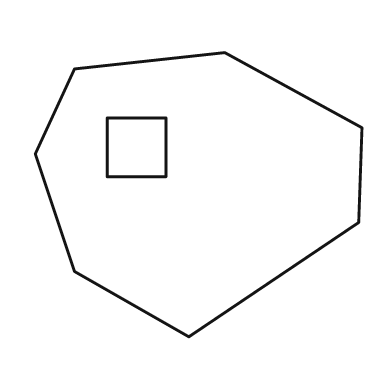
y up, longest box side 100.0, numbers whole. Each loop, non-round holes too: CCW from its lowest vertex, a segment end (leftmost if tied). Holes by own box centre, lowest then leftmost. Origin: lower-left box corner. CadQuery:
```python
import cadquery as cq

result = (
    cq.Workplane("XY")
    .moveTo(47.0, 0.0)
    .lineTo(99.0, 35.0)
    .lineTo(100.0, 64.0)
    .lineTo(58.0, 87.0)
    .lineTo(12.0, 82.0)
    .lineTo(0.0, 56.0)
    .lineTo(12.0, 20.0)
    .close()
    .moveTo(22.0, 49.0)
    .lineTo(40.0, 49.0)
    .lineTo(40.0, 67.0)
    .lineTo(22.0, 67.0)
    .close()
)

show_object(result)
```